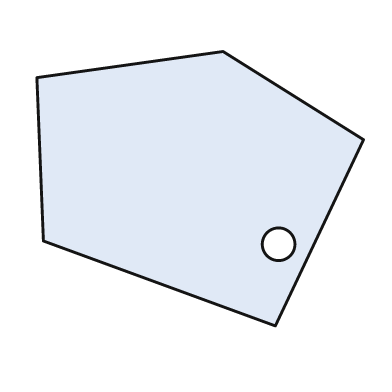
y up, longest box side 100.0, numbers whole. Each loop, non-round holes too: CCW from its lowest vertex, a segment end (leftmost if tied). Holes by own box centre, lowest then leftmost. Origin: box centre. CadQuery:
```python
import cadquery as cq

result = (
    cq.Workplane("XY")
    .moveTo(23.0, -42.0)
    .lineTo(50.0, 15.0)
    .lineTo(7.0, 42.0)
    .lineTo(-50.0, 34.0)
    .lineTo(-48.0, -16.0)
    .close()
    .moveTo(24.0, -17.0)
    .circle(5.0)
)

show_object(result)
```